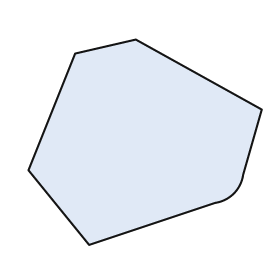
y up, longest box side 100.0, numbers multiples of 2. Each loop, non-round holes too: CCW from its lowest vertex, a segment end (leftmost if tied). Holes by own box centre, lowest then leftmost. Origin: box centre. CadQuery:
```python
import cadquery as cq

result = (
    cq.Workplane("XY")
    .moveTo(-24.0, -44.0)
    .lineTo(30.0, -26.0)
    .threePointArc((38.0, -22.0), (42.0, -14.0))
    .lineTo(50.0, 14.0)
    .lineTo(-4.0, 44.0)
    .lineTo(-30.0, 38.0)
    .lineTo(-50.0, -12.0)
    .close()
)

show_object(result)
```